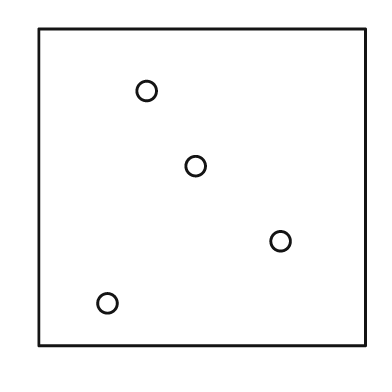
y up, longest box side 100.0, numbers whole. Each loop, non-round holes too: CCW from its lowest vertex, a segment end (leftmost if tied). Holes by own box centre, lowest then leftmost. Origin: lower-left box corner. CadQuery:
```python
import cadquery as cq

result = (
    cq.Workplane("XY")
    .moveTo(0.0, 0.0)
    .lineTo(100.0, 0.0)
    .lineTo(100.0, 97.0)
    .lineTo(0.0, 97.0)
    .close()
    .moveTo(21.0, 13.0)
    .circle(3.0)
    .moveTo(74.0, 32.0)
    .circle(3.0)
    .moveTo(48.0, 55.0)
    .circle(3.0)
    .moveTo(33.0, 78.0)
    .circle(3.0)
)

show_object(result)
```